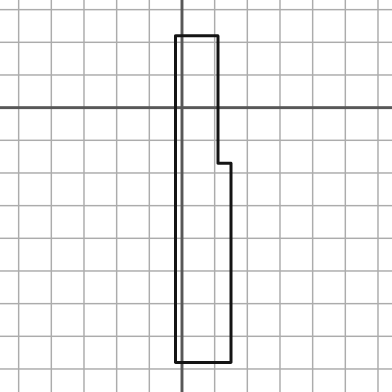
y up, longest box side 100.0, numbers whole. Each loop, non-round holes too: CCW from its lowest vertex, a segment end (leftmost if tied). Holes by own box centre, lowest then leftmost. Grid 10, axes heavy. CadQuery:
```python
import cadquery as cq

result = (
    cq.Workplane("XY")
    .moveTo(-2.0, -78.0)
    .lineTo(15.0, -78.0)
    .lineTo(15.0, -17.0)
    .lineTo(11.0, -17.0)
    .lineTo(11.0, 22.0)
    .lineTo(-2.0, 22.0)
    .close()
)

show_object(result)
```